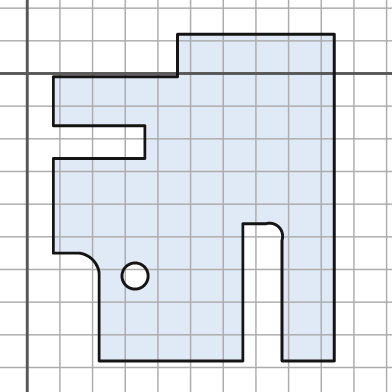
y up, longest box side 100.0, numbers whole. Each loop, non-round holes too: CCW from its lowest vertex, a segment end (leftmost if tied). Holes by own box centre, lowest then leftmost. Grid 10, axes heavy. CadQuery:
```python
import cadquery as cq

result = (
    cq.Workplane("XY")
    .moveTo(22.0, -88.0)
    .lineTo(66.0, -88.0)
    .lineTo(66.0, -46.0)
    .lineTo(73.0, -46.0)
    .threePointArc((77.0, -47.0), (78.0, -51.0))
    .lineTo(78.0, -88.0)
    .lineTo(94.0, -88.0)
    .lineTo(94.0, 12.0)
    .lineTo(46.0, 12.0)
    .lineTo(46.0, -1.0)
    .lineTo(8.0, -1.0)
    .lineTo(8.0, -16.0)
    .lineTo(36.0, -16.0)
    .lineTo(36.0, -26.0)
    .lineTo(8.0, -26.0)
    .lineTo(8.0, -55.0)
    .lineTo(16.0, -55.0)
    .threePointArc((20.0, -57.0), (22.0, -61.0))
    .close()
    .moveTo(33.0, -62.0)
    .circle(4.0)
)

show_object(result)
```